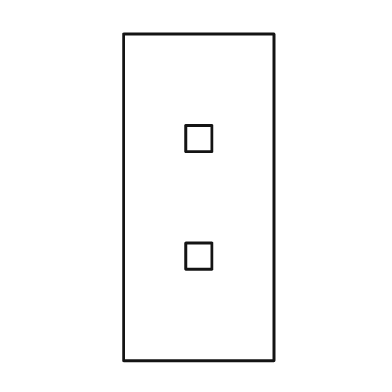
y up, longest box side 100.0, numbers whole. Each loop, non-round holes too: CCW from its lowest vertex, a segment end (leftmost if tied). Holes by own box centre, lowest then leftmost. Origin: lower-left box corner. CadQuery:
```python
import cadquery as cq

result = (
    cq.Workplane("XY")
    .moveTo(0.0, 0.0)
    .lineTo(46.0, 0.0)
    .lineTo(46.0, 100.0)
    .lineTo(0.0, 100.0)
    .close()
    .moveTo(19.0, 28.0)
    .lineTo(27.0, 28.0)
    .lineTo(27.0, 36.0)
    .lineTo(19.0, 36.0)
    .close()
    .moveTo(19.0, 64.0)
    .lineTo(27.0, 64.0)
    .lineTo(27.0, 72.0)
    .lineTo(19.0, 72.0)
    .close()
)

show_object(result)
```